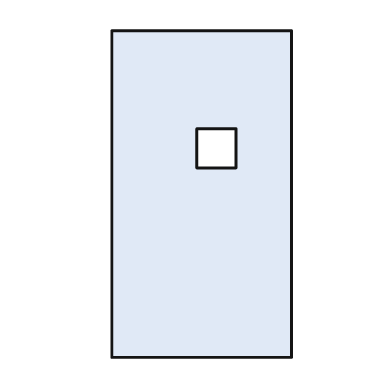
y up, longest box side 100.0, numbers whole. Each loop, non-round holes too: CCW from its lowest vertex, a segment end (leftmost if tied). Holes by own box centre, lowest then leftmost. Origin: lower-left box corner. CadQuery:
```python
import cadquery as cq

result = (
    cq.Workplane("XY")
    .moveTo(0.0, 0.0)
    .lineTo(55.0, 0.0)
    .lineTo(55.0, 100.0)
    .lineTo(0.0, 100.0)
    .close()
    .moveTo(26.0, 58.0)
    .lineTo(38.0, 58.0)
    .lineTo(38.0, 70.0)
    .lineTo(26.0, 70.0)
    .close()
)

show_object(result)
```